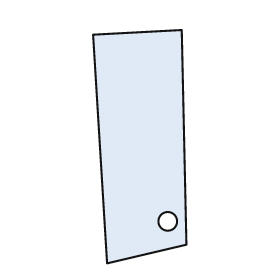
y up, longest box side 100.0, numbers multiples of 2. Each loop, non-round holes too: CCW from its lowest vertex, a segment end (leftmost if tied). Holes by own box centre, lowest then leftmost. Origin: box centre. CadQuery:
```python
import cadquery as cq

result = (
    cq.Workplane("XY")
    .moveTo(-14.0, -50.0)
    .lineTo(20.0, -42.0)
    .lineTo(18.0, 50.0)
    .lineTo(-20.0, 48.0)
    .close()
    .moveTo(12.0, -32.0)
    .circle(4.0)
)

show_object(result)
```